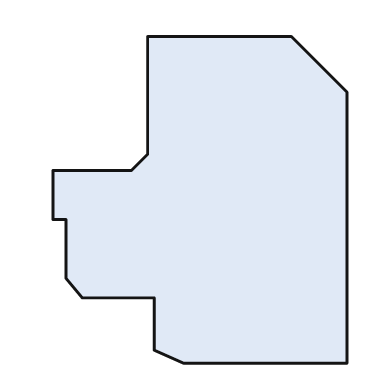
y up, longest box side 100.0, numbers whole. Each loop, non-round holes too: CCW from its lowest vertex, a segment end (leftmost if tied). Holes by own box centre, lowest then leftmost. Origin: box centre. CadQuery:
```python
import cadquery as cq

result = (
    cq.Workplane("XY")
    .moveTo(-5.0, -50.0)
    .lineTo(45.0, -50.0)
    .lineTo(45.0, 33.0)
    .lineTo(28.0, 50.0)
    .lineTo(-16.0, 50.0)
    .lineTo(-16.0, 14.0)
    .lineTo(-21.0, 9.0)
    .lineTo(-45.0, 9.0)
    .lineTo(-45.0, -6.0)
    .lineTo(-41.0, -6.0)
    .lineTo(-41.0, -24.0)
    .lineTo(-36.0, -30.0)
    .lineTo(-14.0, -30.0)
    .lineTo(-14.0, -46.0)
    .close()
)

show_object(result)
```